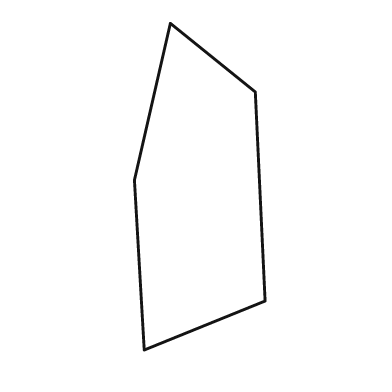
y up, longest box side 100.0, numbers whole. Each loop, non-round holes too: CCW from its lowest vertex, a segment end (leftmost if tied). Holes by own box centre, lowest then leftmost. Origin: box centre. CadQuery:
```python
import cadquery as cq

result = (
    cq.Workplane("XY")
    .moveTo(-17.0, -50.0)
    .lineTo(20.0, -35.0)
    .lineTo(17.0, 29.0)
    .lineTo(-9.0, 50.0)
    .lineTo(-20.0, 2.0)
    .close()
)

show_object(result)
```